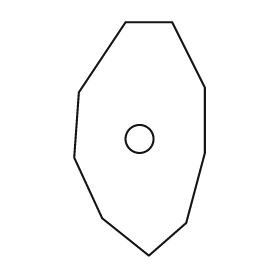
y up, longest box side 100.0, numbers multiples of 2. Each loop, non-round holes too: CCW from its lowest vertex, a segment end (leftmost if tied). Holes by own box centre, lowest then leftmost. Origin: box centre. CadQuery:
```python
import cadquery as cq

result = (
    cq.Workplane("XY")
    .moveTo(4.0, -50.0)
    .lineTo(20.0, -36.0)
    .lineTo(28.0, -6.0)
    .lineTo(28.0, 22.0)
    .lineTo(14.0, 50.0)
    .lineTo(-6.0, 50.0)
    .lineTo(-26.0, 20.0)
    .lineTo(-28.0, -8.0)
    .lineTo(-16.0, -34.0)
    .close()
    .moveTo(0.0, 0.0)
    .circle(6.0)
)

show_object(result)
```